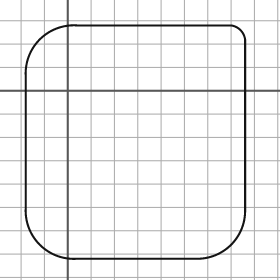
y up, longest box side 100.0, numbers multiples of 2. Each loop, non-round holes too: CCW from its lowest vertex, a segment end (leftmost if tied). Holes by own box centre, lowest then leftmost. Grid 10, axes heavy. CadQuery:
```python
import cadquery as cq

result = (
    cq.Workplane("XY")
    .moveTo(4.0, -72.0)
    .lineTo(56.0, -72.0)
    .threePointArc((70.0, -66.0), (76.0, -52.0))
    .lineTo(76.0, 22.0)
    .threePointArc((74.0, 26.0), (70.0, 28.0))
    .lineTo(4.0, 28.0)
    .threePointArc((-12.0, 22.0), (-18.0, 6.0))
    .lineTo(-18.0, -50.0)
    .threePointArc((-12.0, -66.0), (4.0, -72.0))
    .close()
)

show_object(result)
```